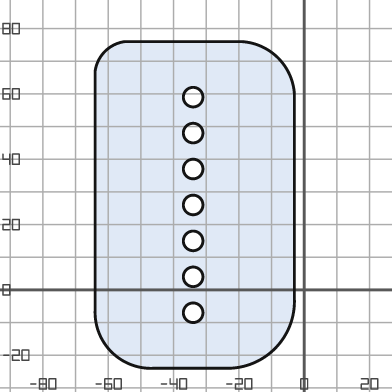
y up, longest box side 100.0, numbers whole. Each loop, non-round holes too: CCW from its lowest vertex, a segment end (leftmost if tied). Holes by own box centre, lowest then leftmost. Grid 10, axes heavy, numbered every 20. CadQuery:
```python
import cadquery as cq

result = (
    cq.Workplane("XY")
    .moveTo(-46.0, -24.0)
    .lineTo(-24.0, -24.0)
    .threePointArc((-9.0, -18.0), (-3.0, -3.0))
    .lineTo(-3.0, 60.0)
    .threePointArc((-8.0, 71.0), (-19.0, 76.0))
    .lineTo(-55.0, 76.0)
    .threePointArc((-61.0, 73.0), (-64.0, 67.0))
    .lineTo(-64.0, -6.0)
    .threePointArc((-59.0, -19.0), (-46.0, -24.0))
    .close()
    .moveTo(-34.0, -7.0)
    .circle(3.0)
    .moveTo(-34.0, 4.0)
    .circle(3.0)
    .moveTo(-34.0, 15.0)
    .circle(3.0)
    .moveTo(-34.0, 26.0)
    .circle(3.0)
    .moveTo(-34.0, 37.0)
    .circle(3.0)
    .moveTo(-34.0, 48.0)
    .circle(3.0)
    .moveTo(-34.0, 59.0)
    .circle(3.0)
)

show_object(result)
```